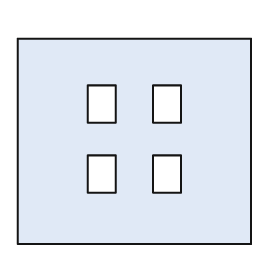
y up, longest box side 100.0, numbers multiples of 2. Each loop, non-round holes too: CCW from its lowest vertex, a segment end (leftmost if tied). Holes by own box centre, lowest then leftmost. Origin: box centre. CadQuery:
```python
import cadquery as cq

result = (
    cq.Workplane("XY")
    .moveTo(-50.0, -44.0)
    .lineTo(50.0, -44.0)
    .lineTo(50.0, 44.0)
    .lineTo(-50.0, 44.0)
    .close()
    .moveTo(-20.0, -22.0)
    .lineTo(-8.0, -22.0)
    .lineTo(-8.0, -6.0)
    .lineTo(-20.0, -6.0)
    .close()
    .moveTo(8.0, -22.0)
    .lineTo(20.0, -22.0)
    .lineTo(20.0, -6.0)
    .lineTo(8.0, -6.0)
    .close()
    .moveTo(-20.0, 8.0)
    .lineTo(-8.0, 8.0)
    .lineTo(-8.0, 24.0)
    .lineTo(-20.0, 24.0)
    .close()
    .moveTo(8.0, 8.0)
    .lineTo(20.0, 8.0)
    .lineTo(20.0, 24.0)
    .lineTo(8.0, 24.0)
    .close()
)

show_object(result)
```